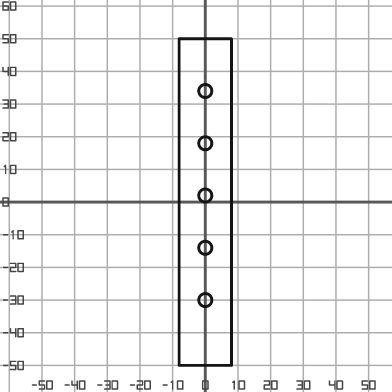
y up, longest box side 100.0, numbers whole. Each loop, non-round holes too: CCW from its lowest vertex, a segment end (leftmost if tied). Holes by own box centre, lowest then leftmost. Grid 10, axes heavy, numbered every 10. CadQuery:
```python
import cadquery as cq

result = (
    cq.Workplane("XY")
    .moveTo(-8.0, -50.0)
    .lineTo(8.0, -50.0)
    .lineTo(8.0, 50.0)
    .lineTo(-8.0, 50.0)
    .close()
    .moveTo(0.0, -30.0)
    .circle(2.0)
    .moveTo(0.0, -14.0)
    .circle(2.0)
    .moveTo(0.0, 2.0)
    .circle(2.0)
    .moveTo(0.0, 18.0)
    .circle(2.0)
    .moveTo(0.0, 34.0)
    .circle(2.0)
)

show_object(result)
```